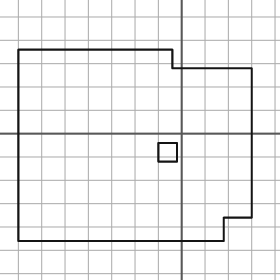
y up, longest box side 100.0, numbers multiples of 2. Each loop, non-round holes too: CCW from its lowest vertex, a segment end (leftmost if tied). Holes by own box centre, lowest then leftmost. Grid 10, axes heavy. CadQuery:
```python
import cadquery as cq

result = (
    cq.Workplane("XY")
    .moveTo(-70.0, -46.0)
    .lineTo(18.0, -46.0)
    .lineTo(18.0, -36.0)
    .lineTo(30.0, -36.0)
    .lineTo(30.0, 28.0)
    .lineTo(-4.0, 28.0)
    .lineTo(-4.0, 36.0)
    .lineTo(-70.0, 36.0)
    .close()
    .moveTo(-10.0, -12.0)
    .lineTo(-2.0, -12.0)
    .lineTo(-2.0, -4.0)
    .lineTo(-10.0, -4.0)
    .close()
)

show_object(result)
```